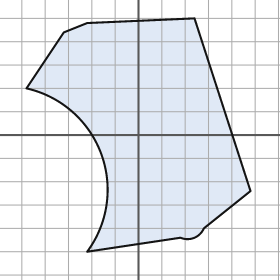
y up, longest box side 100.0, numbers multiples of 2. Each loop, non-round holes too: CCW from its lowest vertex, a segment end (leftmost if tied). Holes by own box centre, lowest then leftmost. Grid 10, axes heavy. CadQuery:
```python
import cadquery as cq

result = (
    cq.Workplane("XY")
    .moveTo(-22.0, -50.0)
    .lineTo(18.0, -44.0)
    .threePointArc((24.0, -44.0), (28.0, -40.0))
    .lineTo(48.0, -24.0)
    .lineTo(24.0, 50.0)
    .lineTo(-22.0, 48.0)
    .lineTo(-32.0, 44.0)
    .lineTo(-48.0, 20.0)
    .threePointArc((-16.0, -8.0), (-22.0, -50.0))
    .close()
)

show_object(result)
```